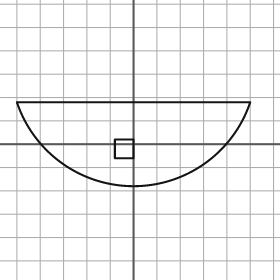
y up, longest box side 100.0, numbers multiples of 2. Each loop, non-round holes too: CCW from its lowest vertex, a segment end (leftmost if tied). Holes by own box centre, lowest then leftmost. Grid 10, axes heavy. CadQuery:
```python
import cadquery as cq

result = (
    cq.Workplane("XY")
    .moveTo(-50.0, 18.0)
    .threePointArc((0.0, -18.0), (50.0, 18.0))
    .close()
    .moveTo(-8.0, -6.0)
    .lineTo(0.0, -6.0)
    .lineTo(0.0, 2.0)
    .lineTo(-8.0, 2.0)
    .close()
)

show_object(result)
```